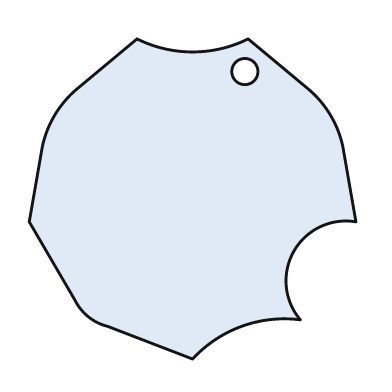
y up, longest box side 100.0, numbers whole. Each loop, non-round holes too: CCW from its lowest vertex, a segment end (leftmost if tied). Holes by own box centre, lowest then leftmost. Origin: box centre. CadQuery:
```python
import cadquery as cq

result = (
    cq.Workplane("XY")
    .moveTo(0.0, -49.0)
    .threePointArc((15.0, -39.0), (33.0, -37.0))
    .threePointArc((31.0, -16.0), (50.0, -7.0))
    .lineTo(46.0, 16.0)
    .threePointArc((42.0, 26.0), (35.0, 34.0))
    .lineTo(17.0, 49.0)
    .threePointArc((0.0, 45.0), (-17.0, 49.0))
    .lineTo(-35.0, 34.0)
    .threePointArc((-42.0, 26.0), (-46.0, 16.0))
    .lineTo(-50.0, -7.0)
    .lineTo(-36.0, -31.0)
    .threePointArc((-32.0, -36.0), (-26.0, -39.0))
    .close()
    .moveTo(16.0, 39.0)
    .circle(4.0)
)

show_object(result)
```